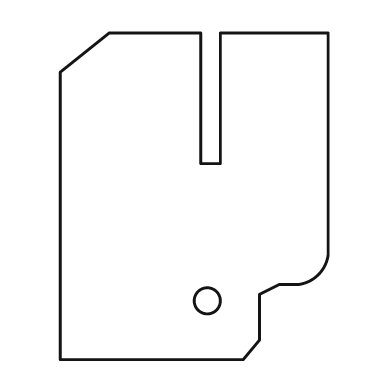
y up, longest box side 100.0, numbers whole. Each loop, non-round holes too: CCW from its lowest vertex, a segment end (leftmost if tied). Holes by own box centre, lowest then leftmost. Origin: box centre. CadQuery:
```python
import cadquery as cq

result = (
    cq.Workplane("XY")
    .moveTo(-41.0, -50.0)
    .lineTo(15.0, -50.0)
    .lineTo(20.0, -44.0)
    .lineTo(20.0, -30.0)
    .lineTo(26.0, -27.0)
    .lineTo(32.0, -27.0)
    .threePointArc((38.0, -24.0), (41.0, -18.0))
    .lineTo(41.0, 50.0)
    .lineTo(8.0, 50.0)
    .lineTo(8.0, 10.0)
    .lineTo(2.0, 10.0)
    .lineTo(2.0, 50.0)
    .lineTo(-26.0, 50.0)
    .lineTo(-41.0, 38.0)
    .close()
    .moveTo(4.0, -32.0)
    .circle(4.0)
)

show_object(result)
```